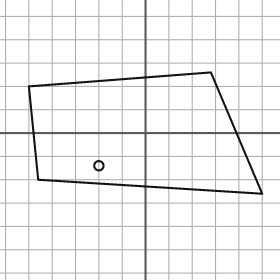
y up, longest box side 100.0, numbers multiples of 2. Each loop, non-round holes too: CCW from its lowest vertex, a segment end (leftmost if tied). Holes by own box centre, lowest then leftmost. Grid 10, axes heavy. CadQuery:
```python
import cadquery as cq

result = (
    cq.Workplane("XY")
    .moveTo(50.0, -26.0)
    .lineTo(28.0, 26.0)
    .lineTo(-50.0, 20.0)
    .lineTo(-46.0, -20.0)
    .close()
    .moveTo(-20.0, -14.0)
    .circle(2.0)
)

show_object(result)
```